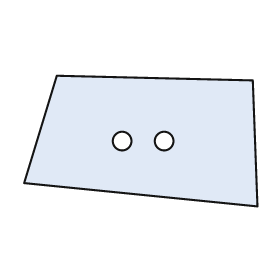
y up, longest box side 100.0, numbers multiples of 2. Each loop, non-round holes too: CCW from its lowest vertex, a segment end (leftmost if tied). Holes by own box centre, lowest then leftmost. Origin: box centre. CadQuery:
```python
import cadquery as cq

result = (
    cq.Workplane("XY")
    .moveTo(50.0, -28.0)
    .lineTo(48.0, 26.0)
    .lineTo(-36.0, 28.0)
    .lineTo(-50.0, -18.0)
    .close()
    .moveTo(-8.0, 0.0)
    .circle(4.0)
    .moveTo(10.0, 0.0)
    .circle(4.0)
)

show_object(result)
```